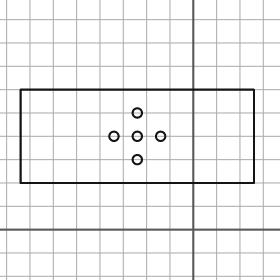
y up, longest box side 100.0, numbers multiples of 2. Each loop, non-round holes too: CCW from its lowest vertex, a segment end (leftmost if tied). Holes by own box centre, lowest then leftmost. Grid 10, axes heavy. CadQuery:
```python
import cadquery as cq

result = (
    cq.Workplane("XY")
    .moveTo(-74.0, 20.0)
    .lineTo(26.0, 20.0)
    .lineTo(26.0, 60.0)
    .lineTo(-74.0, 60.0)
    .close()
    .moveTo(-24.0, 30.0)
    .circle(2.0)
    .moveTo(-34.0, 40.0)
    .circle(2.0)
    .moveTo(-24.0, 40.0)
    .circle(2.0)
    .moveTo(-14.0, 40.0)
    .circle(2.0)
    .moveTo(-24.0, 50.0)
    .circle(2.0)
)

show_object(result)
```